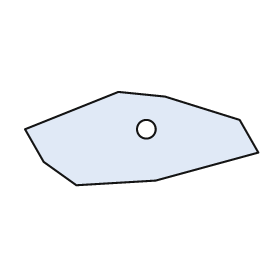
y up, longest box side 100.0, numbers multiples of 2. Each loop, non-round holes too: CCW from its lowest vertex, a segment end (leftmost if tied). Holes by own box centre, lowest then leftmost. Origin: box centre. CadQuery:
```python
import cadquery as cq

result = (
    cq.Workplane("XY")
    .moveTo(-28.0, -20.0)
    .lineTo(6.0, -18.0)
    .lineTo(50.0, -6.0)
    .lineTo(42.0, 8.0)
    .lineTo(10.0, 18.0)
    .lineTo(-10.0, 20.0)
    .lineTo(-50.0, 4.0)
    .lineTo(-42.0, -10.0)
    .close()
    .moveTo(2.0, 4.0)
    .circle(4.0)
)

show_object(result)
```